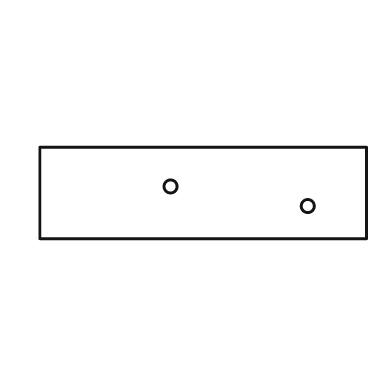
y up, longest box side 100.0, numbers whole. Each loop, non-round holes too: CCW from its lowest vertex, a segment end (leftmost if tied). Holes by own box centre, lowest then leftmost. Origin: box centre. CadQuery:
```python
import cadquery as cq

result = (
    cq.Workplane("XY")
    .moveTo(-50.0, -14.0)
    .lineTo(50.0, -14.0)
    .lineTo(50.0, 14.0)
    .lineTo(-50.0, 14.0)
    .close()
    .moveTo(32.0, -4.0)
    .circle(2.0)
    .moveTo(-10.0, 2.0)
    .circle(2.0)
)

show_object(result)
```